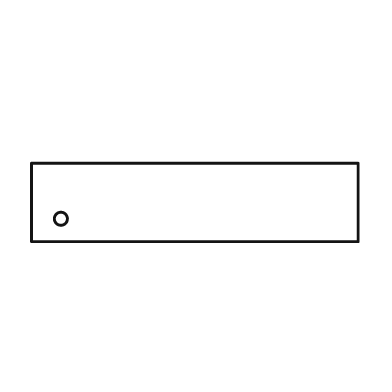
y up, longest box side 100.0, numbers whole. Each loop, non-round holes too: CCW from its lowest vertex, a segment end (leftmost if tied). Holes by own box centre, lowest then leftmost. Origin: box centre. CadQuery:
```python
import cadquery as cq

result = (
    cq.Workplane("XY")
    .moveTo(-50.0, -12.0)
    .lineTo(50.0, -12.0)
    .lineTo(50.0, 12.0)
    .lineTo(-50.0, 12.0)
    .close()
    .moveTo(-41.0, -5.0)
    .circle(2.0)
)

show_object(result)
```